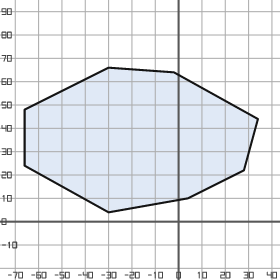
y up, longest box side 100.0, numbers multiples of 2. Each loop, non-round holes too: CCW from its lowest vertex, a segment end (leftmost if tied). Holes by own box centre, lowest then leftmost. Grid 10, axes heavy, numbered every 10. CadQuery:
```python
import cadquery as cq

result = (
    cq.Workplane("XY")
    .moveTo(-30.0, 4.0)
    .lineTo(4.0, 10.0)
    .lineTo(28.0, 22.0)
    .lineTo(34.0, 44.0)
    .lineTo(-2.0, 64.0)
    .lineTo(-30.0, 66.0)
    .lineTo(-66.0, 48.0)
    .lineTo(-66.0, 24.0)
    .close()
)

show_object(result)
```